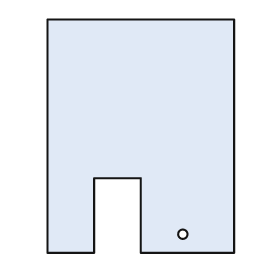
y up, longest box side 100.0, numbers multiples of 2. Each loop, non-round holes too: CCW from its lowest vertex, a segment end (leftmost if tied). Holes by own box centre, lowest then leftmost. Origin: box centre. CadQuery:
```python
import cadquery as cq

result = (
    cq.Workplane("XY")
    .moveTo(-40.0, -50.0)
    .lineTo(-20.0, -50.0)
    .lineTo(-20.0, -18.0)
    .lineTo(0.0, -18.0)
    .lineTo(0.0, -50.0)
    .lineTo(40.0, -50.0)
    .lineTo(40.0, 50.0)
    .lineTo(-40.0, 50.0)
    .close()
    .moveTo(18.0, -42.0)
    .circle(2.0)
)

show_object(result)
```